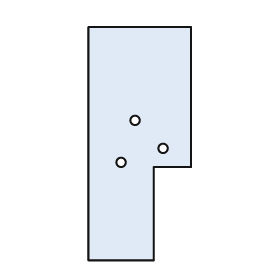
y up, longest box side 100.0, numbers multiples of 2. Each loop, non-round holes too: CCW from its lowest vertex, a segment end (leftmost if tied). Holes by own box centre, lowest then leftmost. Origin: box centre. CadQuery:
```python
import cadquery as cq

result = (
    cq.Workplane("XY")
    .moveTo(-22.0, -50.0)
    .lineTo(6.0, -50.0)
    .lineTo(6.0, -10.0)
    .lineTo(22.0, -10.0)
    .lineTo(22.0, 50.0)
    .lineTo(-22.0, 50.0)
    .close()
    .moveTo(-8.0, -8.0)
    .circle(2.0)
    .moveTo(10.0, -2.0)
    .circle(2.0)
    .moveTo(-2.0, 10.0)
    .circle(2.0)
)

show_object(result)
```